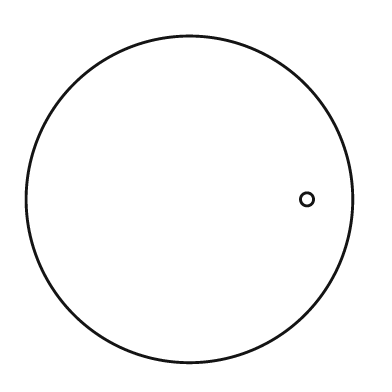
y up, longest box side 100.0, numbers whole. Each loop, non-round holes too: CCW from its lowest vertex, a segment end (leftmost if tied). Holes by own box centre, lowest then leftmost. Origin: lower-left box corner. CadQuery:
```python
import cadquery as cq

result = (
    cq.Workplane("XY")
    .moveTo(50.0, 50.0)
    .circle(50.0)
    .moveTo(86.0, 50.0)
    .circle(2.0)
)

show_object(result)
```